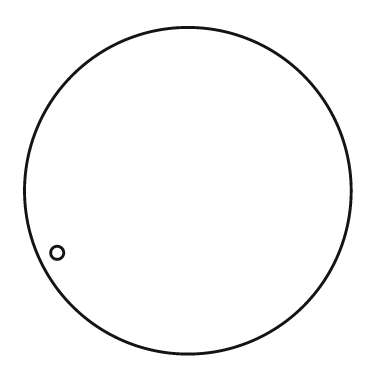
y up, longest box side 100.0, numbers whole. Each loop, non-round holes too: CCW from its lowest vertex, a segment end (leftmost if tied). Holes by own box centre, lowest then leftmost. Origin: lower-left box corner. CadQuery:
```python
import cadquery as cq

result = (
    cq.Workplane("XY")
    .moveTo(50.0, 50.0)
    .circle(50.0)
    .moveTo(10.0, 31.0)
    .circle(2.0)
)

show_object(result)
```